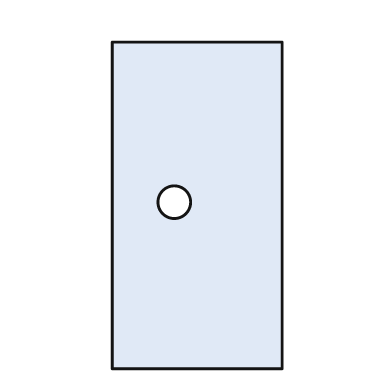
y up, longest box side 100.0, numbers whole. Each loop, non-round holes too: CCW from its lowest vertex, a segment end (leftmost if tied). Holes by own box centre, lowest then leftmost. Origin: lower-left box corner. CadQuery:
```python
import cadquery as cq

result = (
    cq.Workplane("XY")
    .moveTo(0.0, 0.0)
    .lineTo(52.0, 0.0)
    .lineTo(52.0, 100.0)
    .lineTo(0.0, 100.0)
    .close()
    .moveTo(19.0, 51.0)
    .circle(5.0)
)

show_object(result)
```